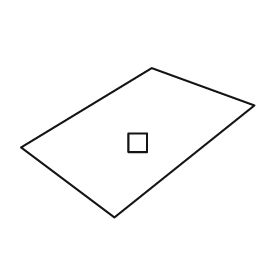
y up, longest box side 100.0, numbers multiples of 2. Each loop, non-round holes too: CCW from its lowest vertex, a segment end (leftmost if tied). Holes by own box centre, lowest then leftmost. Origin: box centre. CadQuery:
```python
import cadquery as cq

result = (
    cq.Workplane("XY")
    .moveTo(-10.0, -32.0)
    .lineTo(50.0, 16.0)
    .lineTo(6.0, 32.0)
    .lineTo(-50.0, -2.0)
    .close()
    .moveTo(-4.0, -4.0)
    .lineTo(4.0, -4.0)
    .lineTo(4.0, 4.0)
    .lineTo(-4.0, 4.0)
    .close()
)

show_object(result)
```